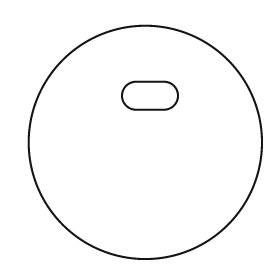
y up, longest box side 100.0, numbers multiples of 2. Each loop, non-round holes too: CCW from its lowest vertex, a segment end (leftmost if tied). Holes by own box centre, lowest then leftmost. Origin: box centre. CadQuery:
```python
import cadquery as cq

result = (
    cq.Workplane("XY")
    .moveTo(0.0, 0.0)
    .circle(50.0)
    .moveTo(-4.0, 14.0)
    .lineTo(8.0, 14.0)
    .threePointArc((14.0, 20.0), (8.0, 26.0))
    .lineTo(-4.0, 26.0)
    .threePointArc((-10.0, 20.0), (-4.0, 14.0))
    .close()
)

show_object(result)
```